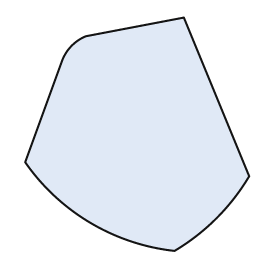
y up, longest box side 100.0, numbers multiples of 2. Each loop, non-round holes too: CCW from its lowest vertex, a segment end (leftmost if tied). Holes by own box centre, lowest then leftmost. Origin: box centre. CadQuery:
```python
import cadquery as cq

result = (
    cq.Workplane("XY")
    .moveTo(16.0, -50.0)
    .threePointArc((34.0, -36.0), (48.0, -18.0))
    .lineTo(20.0, 50.0)
    .lineTo(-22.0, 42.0)
    .threePointArc((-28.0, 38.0), (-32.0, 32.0))
    .lineTo(-48.0, -12.0)
    .threePointArc((-20.0, -38.0), (16.0, -50.0))
    .close()
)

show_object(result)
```